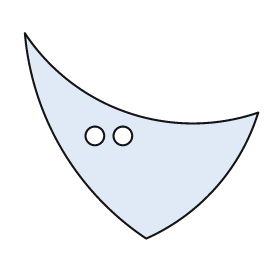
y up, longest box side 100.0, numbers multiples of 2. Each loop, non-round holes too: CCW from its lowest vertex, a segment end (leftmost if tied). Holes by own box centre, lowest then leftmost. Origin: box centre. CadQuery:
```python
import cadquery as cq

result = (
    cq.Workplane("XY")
    .moveTo(2.0, -44.0)
    .threePointArc((32.0, -22.0), (50.0, 10.0))
    .threePointArc((-6.0, 10.0), (-50.0, 44.0))
    .threePointArc((-34.0, -6.0), (2.0, -44.0))
    .close()
    .moveTo(-20.0, 0.0)
    .circle(4.0)
    .moveTo(-8.0, 0.0)
    .circle(4.0)
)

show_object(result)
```